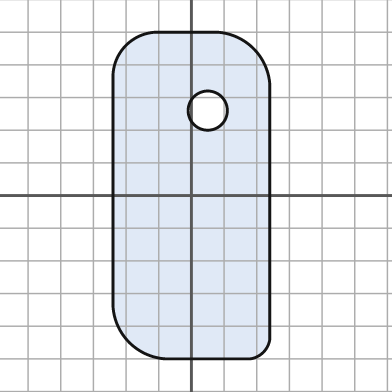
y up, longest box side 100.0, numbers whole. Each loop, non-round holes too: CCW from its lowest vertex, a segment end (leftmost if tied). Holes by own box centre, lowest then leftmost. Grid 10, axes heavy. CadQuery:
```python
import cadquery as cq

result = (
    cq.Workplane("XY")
    .moveTo(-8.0, -50.0)
    .lineTo(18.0, -50.0)
    .threePointArc((22.0, -48.0), (24.0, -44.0))
    .lineTo(24.0, 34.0)
    .threePointArc((19.0, 45.0), (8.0, 50.0))
    .lineTo(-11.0, 50.0)
    .threePointArc((-20.0, 46.0), (-24.0, 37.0))
    .lineTo(-24.0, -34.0)
    .threePointArc((-19.0, -45.0), (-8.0, -50.0))
    .close()
    .moveTo(5.0, 26.0)
    .circle(6.0)
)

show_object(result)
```